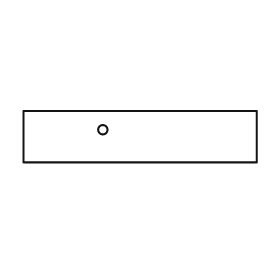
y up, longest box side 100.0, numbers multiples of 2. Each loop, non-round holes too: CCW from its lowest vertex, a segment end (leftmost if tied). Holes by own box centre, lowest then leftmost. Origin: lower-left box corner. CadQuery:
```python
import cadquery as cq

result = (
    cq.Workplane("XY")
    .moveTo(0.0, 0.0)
    .lineTo(100.0, 0.0)
    .lineTo(100.0, 22.0)
    .lineTo(0.0, 22.0)
    .close()
    .moveTo(34.0, 14.0)
    .circle(2.0)
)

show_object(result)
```